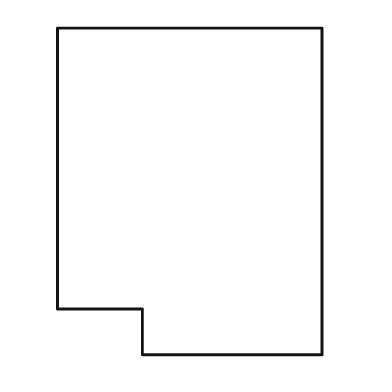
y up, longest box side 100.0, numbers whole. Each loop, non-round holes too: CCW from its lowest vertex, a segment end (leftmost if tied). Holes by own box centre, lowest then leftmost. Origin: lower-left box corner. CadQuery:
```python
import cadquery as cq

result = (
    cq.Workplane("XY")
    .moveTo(26.0, 0.0)
    .lineTo(81.0, 0.0)
    .lineTo(81.0, 100.0)
    .lineTo(0.0, 100.0)
    .lineTo(0.0, 14.0)
    .lineTo(26.0, 14.0)
    .close()
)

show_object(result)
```